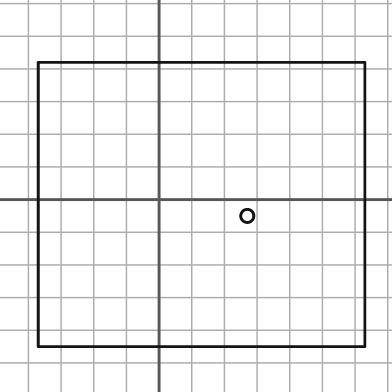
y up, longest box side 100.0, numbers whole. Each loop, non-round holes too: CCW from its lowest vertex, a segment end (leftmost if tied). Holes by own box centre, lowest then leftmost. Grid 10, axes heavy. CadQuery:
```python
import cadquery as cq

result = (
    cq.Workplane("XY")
    .moveTo(-37.0, -45.0)
    .lineTo(63.0, -45.0)
    .lineTo(63.0, 42.0)
    .lineTo(-37.0, 42.0)
    .close()
    .moveTo(27.0, -5.0)
    .circle(2.0)
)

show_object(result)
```